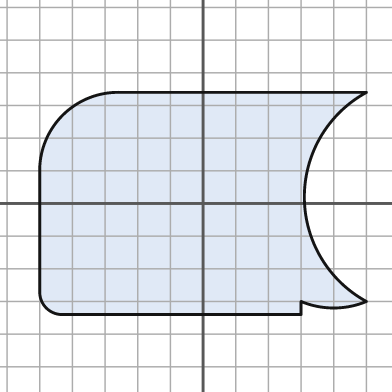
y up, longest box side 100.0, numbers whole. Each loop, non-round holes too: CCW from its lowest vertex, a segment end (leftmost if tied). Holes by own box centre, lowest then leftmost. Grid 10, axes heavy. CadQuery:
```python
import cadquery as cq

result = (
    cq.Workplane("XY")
    .moveTo(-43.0, -34.0)
    .lineTo(30.0, -34.0)
    .lineTo(30.0, -30.0)
    .threePointArc((40.0, -32.0), (50.0, -30.0))
    .threePointArc((31.0, 2.0), (50.0, 34.0))
    .lineTo(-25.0, 34.0)
    .threePointArc((-43.0, 27.0), (-50.0, 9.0))
    .lineTo(-50.0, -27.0)
    .threePointArc((-48.0, -32.0), (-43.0, -34.0))
    .close()
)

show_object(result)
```